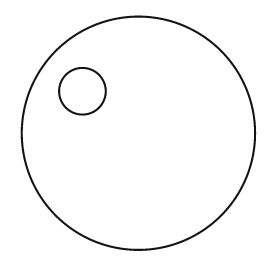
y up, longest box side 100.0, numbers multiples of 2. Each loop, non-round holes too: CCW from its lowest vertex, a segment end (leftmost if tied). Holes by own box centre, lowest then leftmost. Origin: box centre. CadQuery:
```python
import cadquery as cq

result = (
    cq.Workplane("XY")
    .moveTo(0.0, 0.0)
    .circle(50.0)
    .moveTo(-24.0, 18.0)
    .circle(10.0)
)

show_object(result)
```